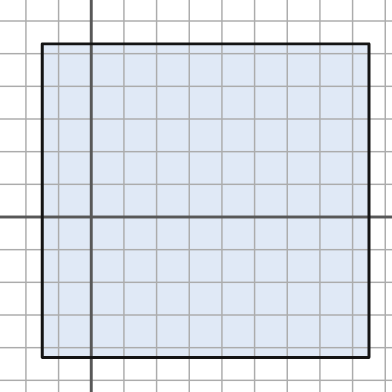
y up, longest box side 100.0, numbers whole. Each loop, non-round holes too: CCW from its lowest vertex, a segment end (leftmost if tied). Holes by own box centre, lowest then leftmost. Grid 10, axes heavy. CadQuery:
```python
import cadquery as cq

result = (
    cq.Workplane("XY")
    .moveTo(-15.0, -43.0)
    .lineTo(85.0, -43.0)
    .lineTo(85.0, 53.0)
    .lineTo(-15.0, 53.0)
    .close()
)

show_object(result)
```